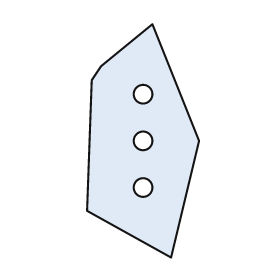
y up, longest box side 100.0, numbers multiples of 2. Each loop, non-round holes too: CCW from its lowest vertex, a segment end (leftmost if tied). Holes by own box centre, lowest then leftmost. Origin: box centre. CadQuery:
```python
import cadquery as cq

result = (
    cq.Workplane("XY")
    .moveTo(12.0, -50.0)
    .lineTo(24.0, 0.0)
    .lineTo(4.0, 50.0)
    .lineTo(-18.0, 32.0)
    .lineTo(-22.0, 26.0)
    .lineTo(-24.0, -30.0)
    .close()
    .moveTo(0.0, -20.0)
    .circle(4.0)
    .moveTo(0.0, 0.0)
    .circle(4.0)
    .moveTo(0.0, 20.0)
    .circle(4.0)
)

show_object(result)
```